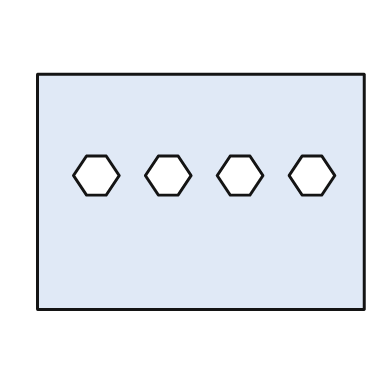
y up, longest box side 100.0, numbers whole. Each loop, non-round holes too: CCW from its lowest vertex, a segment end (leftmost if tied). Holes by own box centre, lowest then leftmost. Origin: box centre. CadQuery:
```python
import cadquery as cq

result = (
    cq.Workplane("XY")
    .moveTo(-50.0, -36.0)
    .lineTo(50.0, -36.0)
    .lineTo(50.0, 36.0)
    .lineTo(-50.0, 36.0)
    .close()
    .moveTo(-35.0, -1.0)
    .lineTo(-29.0, -1.0)
    .lineTo(-25.0, 5.0)
    .lineTo(-29.0, 11.0)
    .lineTo(-35.0, 11.0)
    .lineTo(-39.0, 5.0)
    .close()
    .moveTo(-13.0, -1.0)
    .lineTo(-7.0, -1.0)
    .lineTo(-3.0, 5.0)
    .lineTo(-7.0, 11.0)
    .lineTo(-13.0, 11.0)
    .lineTo(-17.0, 5.0)
    .close()
    .moveTo(9.0, -1.0)
    .lineTo(15.0, -1.0)
    .lineTo(19.0, 5.0)
    .lineTo(15.0, 11.0)
    .lineTo(9.0, 11.0)
    .lineTo(5.0, 5.0)
    .close()
    .moveTo(31.0, -1.0)
    .lineTo(37.0, -1.0)
    .lineTo(41.0, 5.0)
    .lineTo(37.0, 11.0)
    .lineTo(31.0, 11.0)
    .lineTo(27.0, 5.0)
    .close()
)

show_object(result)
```